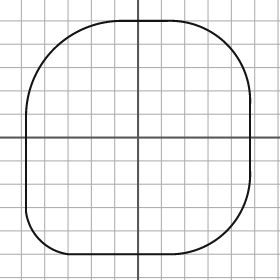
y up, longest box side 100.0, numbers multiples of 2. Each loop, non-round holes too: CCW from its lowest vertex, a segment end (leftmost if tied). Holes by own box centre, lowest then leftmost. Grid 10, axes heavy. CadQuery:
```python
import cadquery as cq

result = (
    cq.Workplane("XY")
    .moveTo(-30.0, -50.0)
    .lineTo(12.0, -50.0)
    .threePointArc((38.0, -40.0), (48.0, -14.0))
    .lineTo(48.0, 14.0)
    .threePointArc((38.0, 40.0), (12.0, 50.0))
    .lineTo(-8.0, 50.0)
    .threePointArc((-36.0, 38.0), (-48.0, 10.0))
    .lineTo(-48.0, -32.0)
    .threePointArc((-42.0, -44.0), (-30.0, -50.0))
    .close()
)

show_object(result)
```